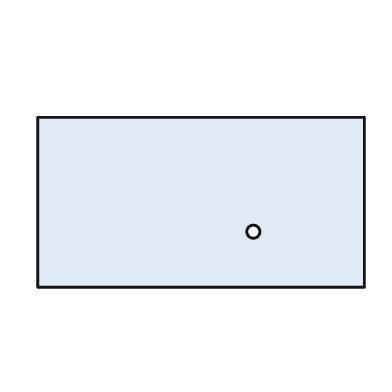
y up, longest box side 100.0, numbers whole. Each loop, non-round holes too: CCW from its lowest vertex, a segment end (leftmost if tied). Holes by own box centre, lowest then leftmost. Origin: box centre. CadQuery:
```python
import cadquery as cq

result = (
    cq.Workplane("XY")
    .moveTo(-50.0, -26.0)
    .lineTo(50.0, -26.0)
    .lineTo(50.0, 26.0)
    .lineTo(-50.0, 26.0)
    .close()
    .moveTo(16.0, -9.0)
    .circle(2.0)
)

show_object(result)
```